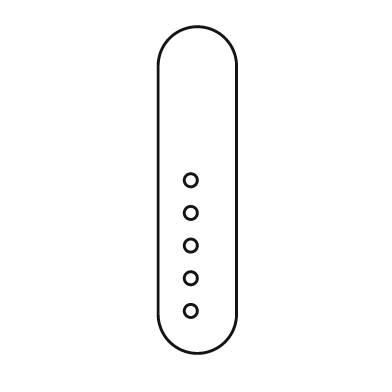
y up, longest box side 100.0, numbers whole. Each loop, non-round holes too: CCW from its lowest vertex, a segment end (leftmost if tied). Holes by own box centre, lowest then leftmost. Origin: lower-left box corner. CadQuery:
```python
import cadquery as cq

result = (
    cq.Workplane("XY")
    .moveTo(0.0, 12.0)
    .threePointArc((12.0, 0.0), (24.0, 12.0))
    .lineTo(24.0, 88.0)
    .threePointArc((12.0, 100.0), (0.0, 88.0))
    .close()
    .moveTo(10.0, 13.0)
    .circle(2.0)
    .moveTo(10.0, 23.0)
    .circle(2.0)
    .moveTo(10.0, 33.0)
    .circle(2.0)
    .moveTo(10.0, 43.0)
    .circle(2.0)
    .moveTo(10.0, 53.0)
    .circle(2.0)
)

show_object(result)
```